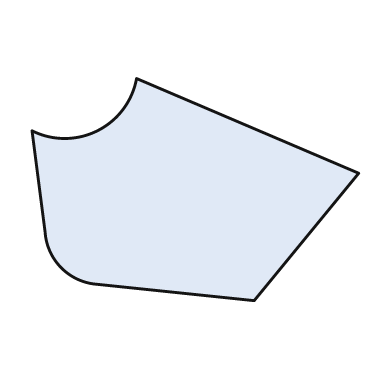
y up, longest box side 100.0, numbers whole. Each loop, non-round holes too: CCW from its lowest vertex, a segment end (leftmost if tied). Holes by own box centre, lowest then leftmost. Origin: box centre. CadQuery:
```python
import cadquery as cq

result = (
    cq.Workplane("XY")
    .moveTo(18.0, -34.0)
    .lineTo(50.0, 5.0)
    .lineTo(-18.0, 34.0)
    .threePointArc((-30.0, 18.0), (-50.0, 18.0))
    .lineTo(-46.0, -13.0)
    .threePointArc((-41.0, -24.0), (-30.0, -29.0))
    .close()
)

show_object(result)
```